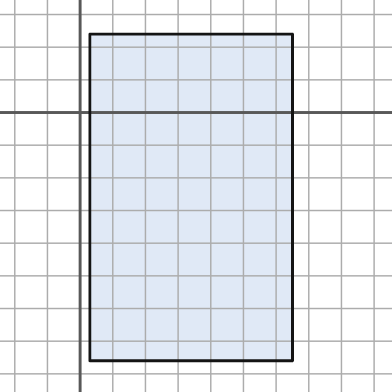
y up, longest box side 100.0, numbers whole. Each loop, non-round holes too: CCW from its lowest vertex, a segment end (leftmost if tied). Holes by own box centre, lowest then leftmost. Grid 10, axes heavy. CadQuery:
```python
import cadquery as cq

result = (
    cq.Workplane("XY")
    .moveTo(3.0, -76.0)
    .lineTo(65.0, -76.0)
    .lineTo(65.0, 24.0)
    .lineTo(3.0, 24.0)
    .close()
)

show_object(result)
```